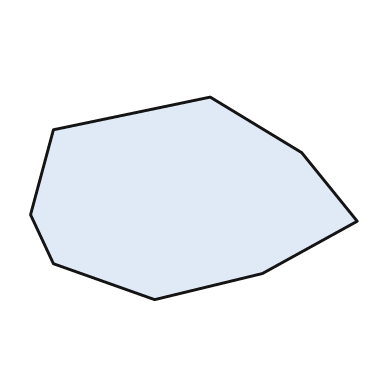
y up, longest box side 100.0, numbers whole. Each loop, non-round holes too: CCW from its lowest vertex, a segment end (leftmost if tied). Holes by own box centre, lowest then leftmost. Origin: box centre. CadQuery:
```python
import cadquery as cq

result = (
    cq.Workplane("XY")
    .moveTo(-12.0, -31.0)
    .lineTo(21.0, -23.0)
    .lineTo(50.0, -7.0)
    .lineTo(33.0, 14.0)
    .lineTo(5.0, 31.0)
    .lineTo(-43.0, 21.0)
    .lineTo(-50.0, -5.0)
    .lineTo(-43.0, -20.0)
    .close()
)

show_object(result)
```